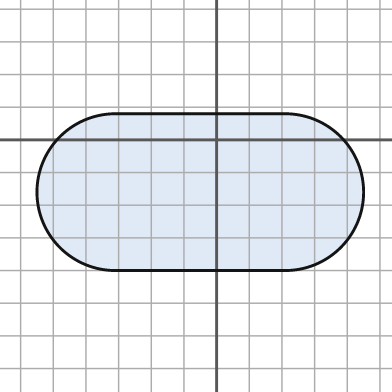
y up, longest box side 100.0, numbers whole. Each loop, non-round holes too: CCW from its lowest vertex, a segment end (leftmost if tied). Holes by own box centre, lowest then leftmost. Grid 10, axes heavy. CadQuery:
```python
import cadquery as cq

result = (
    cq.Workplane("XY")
    .moveTo(-31.0, -40.0)
    .lineTo(21.0, -40.0)
    .threePointArc((45.0, -16.0), (21.0, 8.0))
    .lineTo(-31.0, 8.0)
    .threePointArc((-55.0, -16.0), (-31.0, -40.0))
    .close()
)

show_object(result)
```